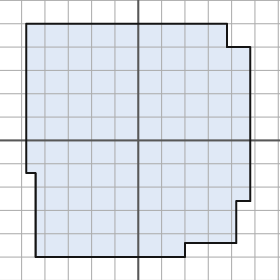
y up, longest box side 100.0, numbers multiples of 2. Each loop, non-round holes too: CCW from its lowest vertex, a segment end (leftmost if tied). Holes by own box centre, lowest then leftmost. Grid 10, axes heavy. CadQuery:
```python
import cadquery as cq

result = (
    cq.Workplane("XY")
    .moveTo(-44.0, -50.0)
    .lineTo(20.0, -50.0)
    .lineTo(20.0, -44.0)
    .lineTo(42.0, -44.0)
    .lineTo(42.0, -26.0)
    .lineTo(48.0, -26.0)
    .lineTo(48.0, 40.0)
    .lineTo(38.0, 40.0)
    .lineTo(38.0, 50.0)
    .lineTo(-48.0, 50.0)
    .lineTo(-48.0, -14.0)
    .lineTo(-44.0, -14.0)
    .close()
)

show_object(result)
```